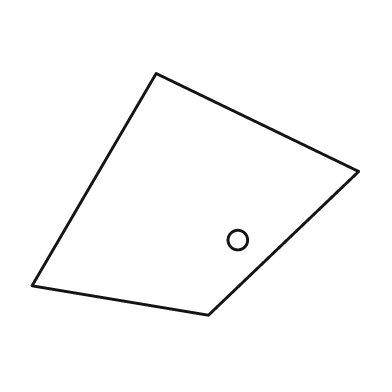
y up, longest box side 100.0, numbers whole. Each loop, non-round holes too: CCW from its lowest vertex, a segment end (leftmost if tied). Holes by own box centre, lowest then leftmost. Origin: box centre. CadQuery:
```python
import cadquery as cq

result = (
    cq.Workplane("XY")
    .moveTo(4.0, -37.0)
    .lineTo(50.0, 7.0)
    .lineTo(-12.0, 37.0)
    .lineTo(-50.0, -28.0)
    .close()
    .moveTo(13.0, -14.0)
    .circle(3.0)
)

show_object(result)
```